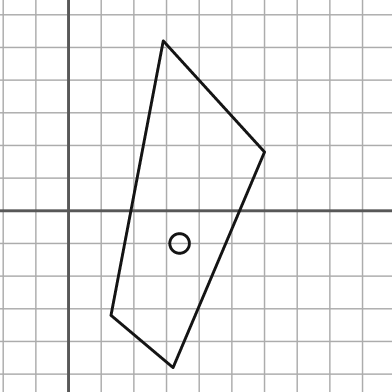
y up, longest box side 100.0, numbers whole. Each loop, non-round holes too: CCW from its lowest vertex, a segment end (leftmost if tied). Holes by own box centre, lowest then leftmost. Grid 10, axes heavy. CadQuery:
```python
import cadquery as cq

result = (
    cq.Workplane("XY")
    .moveTo(32.0, -48.0)
    .lineTo(60.0, 18.0)
    .lineTo(29.0, 52.0)
    .lineTo(13.0, -32.0)
    .close()
    .moveTo(34.0, -10.0)
    .circle(3.0)
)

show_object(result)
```